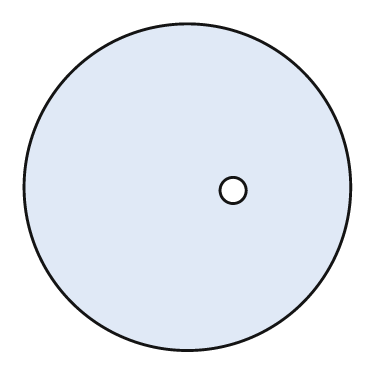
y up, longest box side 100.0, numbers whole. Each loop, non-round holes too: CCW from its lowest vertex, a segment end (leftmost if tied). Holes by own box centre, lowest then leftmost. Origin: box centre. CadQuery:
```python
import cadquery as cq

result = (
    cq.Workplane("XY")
    .moveTo(0.0, 0.0)
    .circle(50.0)
    .moveTo(14.0, -1.0)
    .circle(4.0)
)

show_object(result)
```